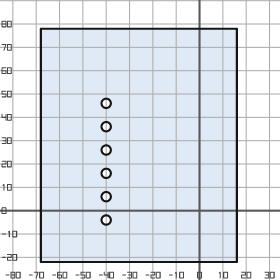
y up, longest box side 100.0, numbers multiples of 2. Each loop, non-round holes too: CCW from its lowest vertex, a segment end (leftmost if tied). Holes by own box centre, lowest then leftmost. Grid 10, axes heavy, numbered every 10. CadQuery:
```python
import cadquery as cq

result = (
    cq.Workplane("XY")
    .moveTo(-68.0, -22.0)
    .lineTo(16.0, -22.0)
    .lineTo(16.0, 78.0)
    .lineTo(-68.0, 78.0)
    .close()
    .moveTo(-40.0, -4.0)
    .circle(2.0)
    .moveTo(-40.0, 6.0)
    .circle(2.0)
    .moveTo(-40.0, 16.0)
    .circle(2.0)
    .moveTo(-40.0, 26.0)
    .circle(2.0)
    .moveTo(-40.0, 36.0)
    .circle(2.0)
    .moveTo(-40.0, 46.0)
    .circle(2.0)
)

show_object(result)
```